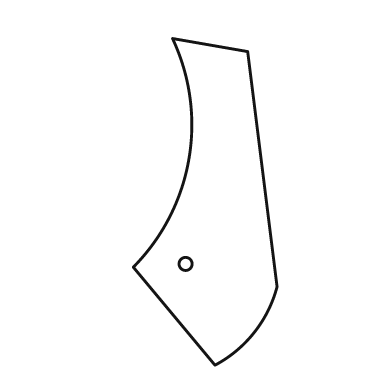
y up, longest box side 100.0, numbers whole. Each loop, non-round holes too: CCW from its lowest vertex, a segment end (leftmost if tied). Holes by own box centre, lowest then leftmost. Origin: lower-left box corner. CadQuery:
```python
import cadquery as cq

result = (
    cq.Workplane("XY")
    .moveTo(25.0, 0.0)
    .threePointArc((37.0, 10.0), (44.0, 24.0))
    .lineTo(35.0, 96.0)
    .lineTo(12.0, 100.0)
    .threePointArc((17.0, 63.0), (0.0, 30.0))
    .close()
    .moveTo(16.0, 31.0)
    .circle(2.0)
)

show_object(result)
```